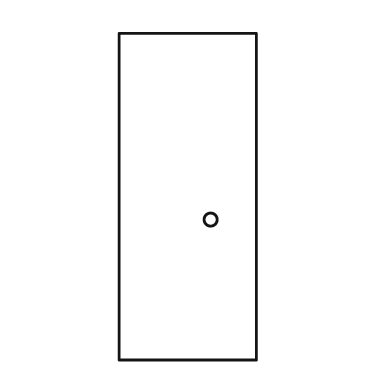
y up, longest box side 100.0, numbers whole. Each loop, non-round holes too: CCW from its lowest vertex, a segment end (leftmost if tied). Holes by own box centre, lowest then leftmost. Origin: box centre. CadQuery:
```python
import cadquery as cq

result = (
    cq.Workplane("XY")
    .moveTo(-21.0, -50.0)
    .lineTo(21.0, -50.0)
    .lineTo(21.0, 50.0)
    .lineTo(-21.0, 50.0)
    .close()
    .moveTo(7.0, -7.0)
    .circle(2.0)
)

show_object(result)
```